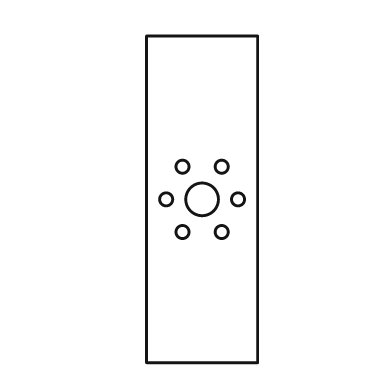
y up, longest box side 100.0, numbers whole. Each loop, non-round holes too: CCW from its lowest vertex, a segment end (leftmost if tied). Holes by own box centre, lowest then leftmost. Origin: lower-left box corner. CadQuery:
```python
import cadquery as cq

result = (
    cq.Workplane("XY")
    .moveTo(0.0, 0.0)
    .lineTo(34.0, 0.0)
    .lineTo(34.0, 100.0)
    .lineTo(0.0, 100.0)
    .close()
    .moveTo(11.0, 40.0)
    .circle(2.0)
    .moveTo(23.0, 40.0)
    .circle(2.0)
    .moveTo(6.0, 50.0)
    .circle(2.0)
    .moveTo(17.0, 50.0)
    .circle(5.0)
    .moveTo(28.0, 50.0)
    .circle(2.0)
    .moveTo(11.0, 60.0)
    .circle(2.0)
    .moveTo(23.0, 60.0)
    .circle(2.0)
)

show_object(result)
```